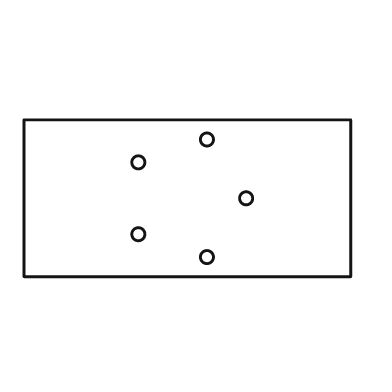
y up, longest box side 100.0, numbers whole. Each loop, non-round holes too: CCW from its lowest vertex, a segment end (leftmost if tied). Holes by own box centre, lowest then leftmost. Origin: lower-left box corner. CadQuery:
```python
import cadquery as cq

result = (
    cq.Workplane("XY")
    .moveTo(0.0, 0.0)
    .lineTo(100.0, 0.0)
    .lineTo(100.0, 48.0)
    .lineTo(0.0, 48.0)
    .close()
    .moveTo(56.0, 6.0)
    .circle(2.0)
    .moveTo(35.0, 13.0)
    .circle(2.0)
    .moveTo(68.0, 24.0)
    .circle(2.0)
    .moveTo(35.0, 35.0)
    .circle(2.0)
    .moveTo(56.0, 42.0)
    .circle(2.0)
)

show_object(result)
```